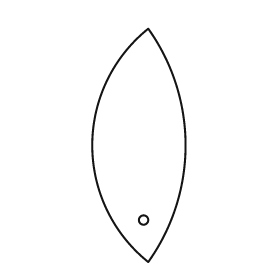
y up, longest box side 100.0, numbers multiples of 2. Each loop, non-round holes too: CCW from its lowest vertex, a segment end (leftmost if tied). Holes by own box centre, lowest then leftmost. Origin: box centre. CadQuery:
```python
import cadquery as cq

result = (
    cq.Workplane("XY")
    .moveTo(4.0, -50.0)
    .threePointArc((20.0, 0.0), (4.0, 50.0))
    .threePointArc((-20.0, 0.0), (4.0, -50.0))
    .close()
    .moveTo(2.0, -32.0)
    .circle(2.0)
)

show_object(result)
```